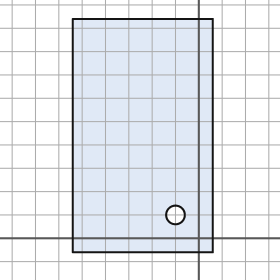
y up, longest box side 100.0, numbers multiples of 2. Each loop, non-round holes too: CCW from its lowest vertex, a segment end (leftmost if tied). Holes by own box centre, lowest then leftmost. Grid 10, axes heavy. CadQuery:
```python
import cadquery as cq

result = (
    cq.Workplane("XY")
    .moveTo(-54.0, -6.0)
    .lineTo(6.0, -6.0)
    .lineTo(6.0, 94.0)
    .lineTo(-54.0, 94.0)
    .close()
    .moveTo(-10.0, 10.0)
    .circle(4.0)
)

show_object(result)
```